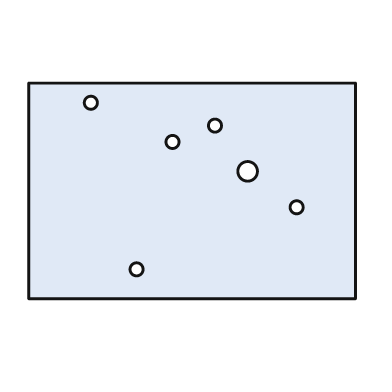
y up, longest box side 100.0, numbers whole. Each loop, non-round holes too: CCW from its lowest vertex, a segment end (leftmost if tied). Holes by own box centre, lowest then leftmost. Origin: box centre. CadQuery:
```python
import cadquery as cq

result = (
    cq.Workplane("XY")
    .moveTo(-50.0, -33.0)
    .lineTo(50.0, -33.0)
    .lineTo(50.0, 33.0)
    .lineTo(-50.0, 33.0)
    .close()
    .moveTo(-17.0, -24.0)
    .circle(2.0)
    .moveTo(32.0, -5.0)
    .circle(2.0)
    .moveTo(17.0, 6.0)
    .circle(3.0)
    .moveTo(-6.0, 15.0)
    .circle(2.0)
    .moveTo(7.0, 20.0)
    .circle(2.0)
    .moveTo(-31.0, 27.0)
    .circle(2.0)
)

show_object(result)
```